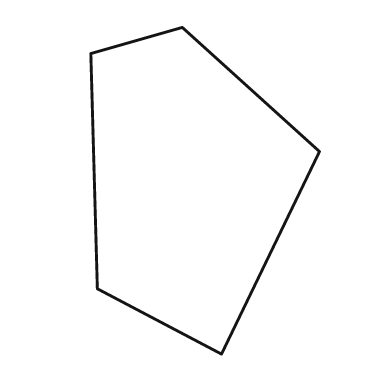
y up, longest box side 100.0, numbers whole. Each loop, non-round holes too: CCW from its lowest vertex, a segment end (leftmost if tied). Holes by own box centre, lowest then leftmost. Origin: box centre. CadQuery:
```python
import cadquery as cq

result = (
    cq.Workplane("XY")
    .moveTo(5.0, -50.0)
    .lineTo(35.0, 12.0)
    .lineTo(-7.0, 50.0)
    .lineTo(-35.0, 42.0)
    .lineTo(-33.0, -30.0)
    .close()
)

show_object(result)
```